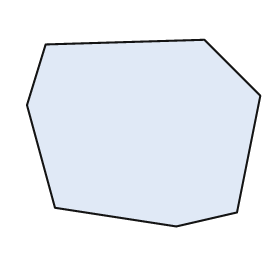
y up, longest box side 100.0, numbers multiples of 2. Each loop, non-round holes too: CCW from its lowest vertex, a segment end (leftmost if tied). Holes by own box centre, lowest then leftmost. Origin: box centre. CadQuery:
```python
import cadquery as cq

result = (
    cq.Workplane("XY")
    .moveTo(14.0, -40.0)
    .lineTo(40.0, -34.0)
    .lineTo(50.0, 16.0)
    .lineTo(26.0, 40.0)
    .lineTo(-42.0, 38.0)
    .lineTo(-50.0, 12.0)
    .lineTo(-38.0, -32.0)
    .close()
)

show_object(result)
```